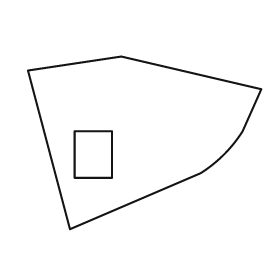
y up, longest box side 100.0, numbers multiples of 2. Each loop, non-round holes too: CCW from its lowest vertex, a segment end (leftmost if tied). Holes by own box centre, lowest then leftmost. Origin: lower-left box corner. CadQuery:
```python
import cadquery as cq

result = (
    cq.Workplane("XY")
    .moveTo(18.0, 0.0)
    .lineTo(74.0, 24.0)
    .threePointArc((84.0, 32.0), (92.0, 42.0))
    .lineTo(100.0, 60.0)
    .lineTo(40.0, 74.0)
    .lineTo(0.0, 68.0)
    .close()
    .moveTo(20.0, 22.0)
    .lineTo(36.0, 22.0)
    .lineTo(36.0, 42.0)
    .lineTo(20.0, 42.0)
    .close()
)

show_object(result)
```